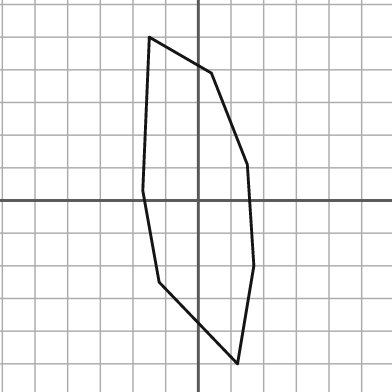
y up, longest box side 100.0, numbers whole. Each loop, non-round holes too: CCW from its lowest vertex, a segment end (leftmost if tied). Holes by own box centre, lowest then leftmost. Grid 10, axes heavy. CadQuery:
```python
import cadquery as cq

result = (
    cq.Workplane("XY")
    .moveTo(12.0, -50.0)
    .lineTo(17.0, -20.0)
    .lineTo(15.0, 11.0)
    .lineTo(4.0, 39.0)
    .lineTo(-15.0, 50.0)
    .lineTo(-17.0, 3.0)
    .lineTo(-12.0, -25.0)
    .close()
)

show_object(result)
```